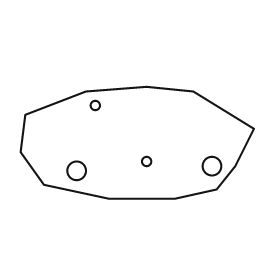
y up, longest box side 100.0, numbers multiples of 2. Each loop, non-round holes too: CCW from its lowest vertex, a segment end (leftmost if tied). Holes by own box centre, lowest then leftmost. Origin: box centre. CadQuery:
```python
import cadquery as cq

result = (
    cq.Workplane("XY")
    .moveTo(-12.0, -24.0)
    .lineTo(16.0, -24.0)
    .lineTo(34.0, -20.0)
    .lineTo(42.0, -10.0)
    .lineTo(50.0, 6.0)
    .lineTo(24.0, 22.0)
    .lineTo(4.0, 24.0)
    .lineTo(-22.0, 22.0)
    .lineTo(-48.0, 12.0)
    .lineTo(-50.0, -4.0)
    .lineTo(-40.0, -18.0)
    .close()
    .moveTo(-26.0, -12.0)
    .circle(4.0)
    .moveTo(32.0, -10.0)
    .circle(4.0)
    .moveTo(4.0, -8.0)
    .circle(2.0)
    .moveTo(-18.0, 16.0)
    .circle(2.0)
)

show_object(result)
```